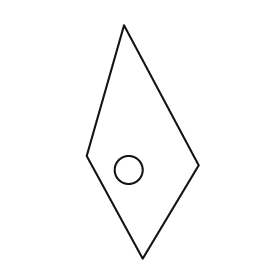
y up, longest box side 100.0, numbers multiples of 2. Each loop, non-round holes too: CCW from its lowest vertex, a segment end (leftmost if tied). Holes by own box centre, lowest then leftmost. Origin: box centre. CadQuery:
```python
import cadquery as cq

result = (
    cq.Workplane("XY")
    .moveTo(0.0, -50.0)
    .lineTo(24.0, -10.0)
    .lineTo(-8.0, 50.0)
    .lineTo(-24.0, -6.0)
    .close()
    .moveTo(-6.0, -12.0)
    .circle(6.0)
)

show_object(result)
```